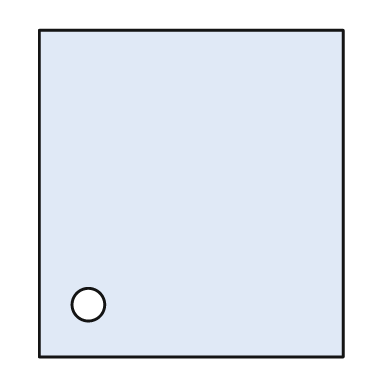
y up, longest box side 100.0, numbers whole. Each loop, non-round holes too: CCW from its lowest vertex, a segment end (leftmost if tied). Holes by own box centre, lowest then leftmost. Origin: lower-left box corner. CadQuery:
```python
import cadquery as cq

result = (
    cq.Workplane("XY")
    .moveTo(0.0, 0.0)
    .lineTo(93.0, 0.0)
    .lineTo(93.0, 100.0)
    .lineTo(0.0, 100.0)
    .close()
    .moveTo(15.0, 16.0)
    .circle(5.0)
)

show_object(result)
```